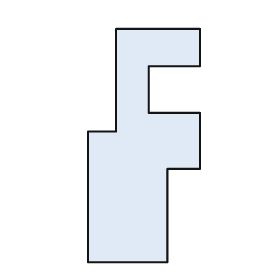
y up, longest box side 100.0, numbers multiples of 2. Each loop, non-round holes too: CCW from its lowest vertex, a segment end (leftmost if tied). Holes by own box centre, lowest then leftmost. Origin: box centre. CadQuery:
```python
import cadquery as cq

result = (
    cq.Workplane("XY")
    .moveTo(-24.0, -50.0)
    .lineTo(10.0, -50.0)
    .lineTo(10.0, -10.0)
    .lineTo(24.0, -10.0)
    .lineTo(24.0, 14.0)
    .lineTo(2.0, 14.0)
    .lineTo(2.0, 34.0)
    .lineTo(24.0, 34.0)
    .lineTo(24.0, 50.0)
    .lineTo(-12.0, 50.0)
    .lineTo(-12.0, 6.0)
    .lineTo(-24.0, 6.0)
    .close()
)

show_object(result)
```